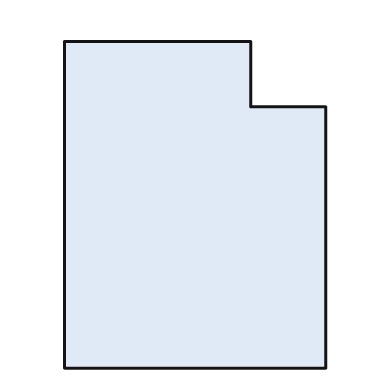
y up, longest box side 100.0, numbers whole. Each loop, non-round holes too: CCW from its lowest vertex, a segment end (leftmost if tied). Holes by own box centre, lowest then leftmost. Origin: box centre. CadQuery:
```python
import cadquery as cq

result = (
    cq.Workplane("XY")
    .moveTo(-40.0, -50.0)
    .lineTo(40.0, -50.0)
    .lineTo(40.0, 30.0)
    .lineTo(17.0, 30.0)
    .lineTo(17.0, 50.0)
    .lineTo(-40.0, 50.0)
    .close()
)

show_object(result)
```